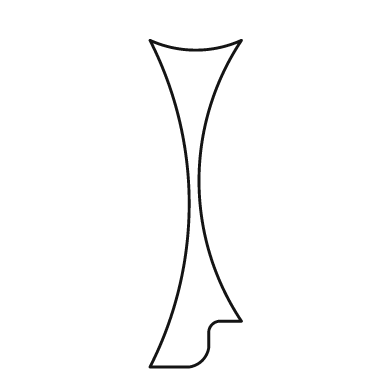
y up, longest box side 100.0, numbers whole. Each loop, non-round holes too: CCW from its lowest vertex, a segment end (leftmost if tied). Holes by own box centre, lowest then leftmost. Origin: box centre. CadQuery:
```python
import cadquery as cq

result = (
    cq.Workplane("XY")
    .moveTo(-14.0, -50.0)
    .lineTo(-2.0, -50.0)
    .threePointArc((2.0, -48.0), (4.0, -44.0))
    .lineTo(4.0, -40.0)
    .threePointArc((5.0, -37.0), (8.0, -36.0))
    .lineTo(14.0, -36.0)
    .threePointArc((1.0, 7.0), (14.0, 50.0))
    .threePointArc((0.0, 47.0), (-14.0, 50.0))
    .threePointArc((-2.0, 0.0), (-14.0, -50.0))
    .close()
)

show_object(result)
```